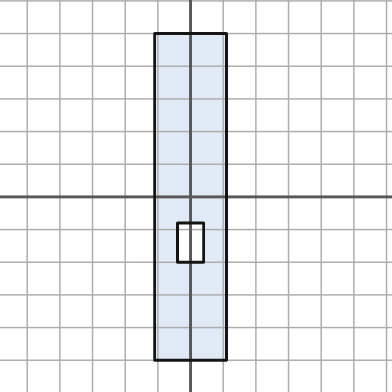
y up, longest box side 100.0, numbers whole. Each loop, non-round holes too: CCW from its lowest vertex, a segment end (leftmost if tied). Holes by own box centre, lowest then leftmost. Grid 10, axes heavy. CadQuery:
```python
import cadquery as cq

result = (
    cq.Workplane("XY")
    .moveTo(-11.0, -50.0)
    .lineTo(11.0, -50.0)
    .lineTo(11.0, 50.0)
    .lineTo(-11.0, 50.0)
    .close()
    .moveTo(-4.0, -20.0)
    .lineTo(4.0, -20.0)
    .lineTo(4.0, -8.0)
    .lineTo(-4.0, -8.0)
    .close()
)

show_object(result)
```